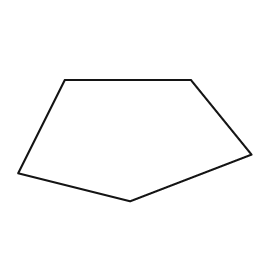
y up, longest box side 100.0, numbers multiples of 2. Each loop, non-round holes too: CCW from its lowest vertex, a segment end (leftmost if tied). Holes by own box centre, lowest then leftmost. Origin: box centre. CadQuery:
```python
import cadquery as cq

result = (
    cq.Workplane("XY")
    .moveTo(-2.0, -26.0)
    .lineTo(50.0, -6.0)
    .lineTo(24.0, 26.0)
    .lineTo(-30.0, 26.0)
    .lineTo(-50.0, -14.0)
    .close()
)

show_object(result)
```